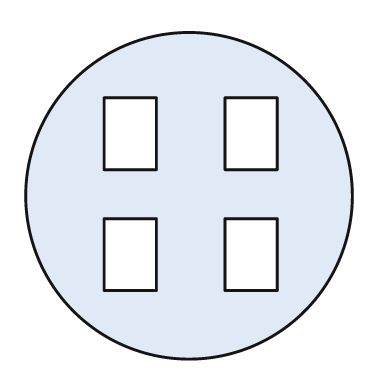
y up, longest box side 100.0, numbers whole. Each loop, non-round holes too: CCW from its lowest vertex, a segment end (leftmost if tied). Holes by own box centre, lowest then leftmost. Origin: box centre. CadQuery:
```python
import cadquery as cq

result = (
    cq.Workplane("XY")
    .moveTo(0.0, 0.0)
    .circle(50.0)
    .moveTo(-26.0, -29.0)
    .lineTo(-10.0, -29.0)
    .lineTo(-10.0, -7.0)
    .lineTo(-26.0, -7.0)
    .close()
    .moveTo(11.0, -29.0)
    .lineTo(27.0, -29.0)
    .lineTo(27.0, -7.0)
    .lineTo(11.0, -7.0)
    .close()
    .moveTo(-26.0, 8.0)
    .lineTo(-10.0, 8.0)
    .lineTo(-10.0, 30.0)
    .lineTo(-26.0, 30.0)
    .close()
    .moveTo(11.0, 8.0)
    .lineTo(27.0, 8.0)
    .lineTo(27.0, 30.0)
    .lineTo(11.0, 30.0)
    .close()
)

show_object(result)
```